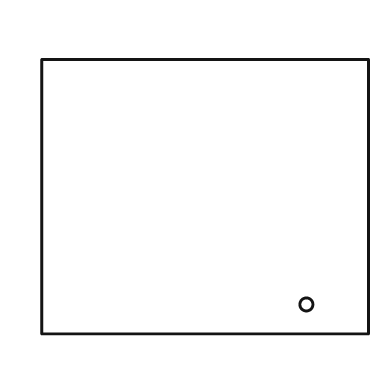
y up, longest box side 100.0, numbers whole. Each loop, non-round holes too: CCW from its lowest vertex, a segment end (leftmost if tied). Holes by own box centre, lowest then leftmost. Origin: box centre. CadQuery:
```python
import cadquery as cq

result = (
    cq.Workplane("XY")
    .moveTo(-50.0, -42.0)
    .lineTo(50.0, -42.0)
    .lineTo(50.0, 42.0)
    .lineTo(-50.0, 42.0)
    .close()
    .moveTo(31.0, -33.0)
    .circle(2.0)
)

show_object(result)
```